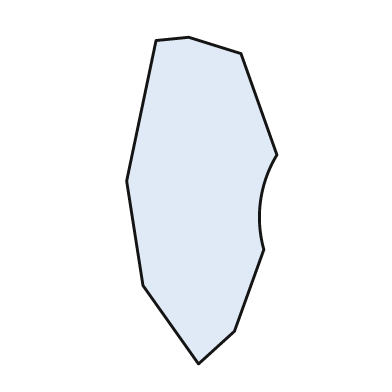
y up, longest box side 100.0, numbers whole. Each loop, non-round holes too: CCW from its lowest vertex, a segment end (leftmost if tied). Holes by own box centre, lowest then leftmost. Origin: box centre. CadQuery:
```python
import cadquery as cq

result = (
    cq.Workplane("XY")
    .moveTo(-1.0, -50.0)
    .lineTo(10.0, -40.0)
    .lineTo(19.0, -15.0)
    .threePointArc((18.0, 0.0), (23.0, 14.0))
    .lineTo(12.0, 45.0)
    .lineTo(-4.0, 50.0)
    .lineTo(-14.0, 49.0)
    .lineTo(-23.0, 6.0)
    .lineTo(-18.0, -26.0)
    .close()
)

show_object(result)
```